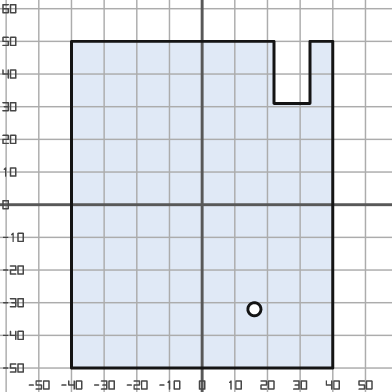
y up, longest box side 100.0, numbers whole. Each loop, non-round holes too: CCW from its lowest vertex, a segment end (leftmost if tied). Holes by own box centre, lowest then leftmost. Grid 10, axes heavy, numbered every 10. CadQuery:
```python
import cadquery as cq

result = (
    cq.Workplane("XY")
    .moveTo(-40.0, -50.0)
    .lineTo(40.0, -50.0)
    .lineTo(40.0, 50.0)
    .lineTo(33.0, 50.0)
    .lineTo(33.0, 31.0)
    .lineTo(22.0, 31.0)
    .lineTo(22.0, 50.0)
    .lineTo(-40.0, 50.0)
    .close()
    .moveTo(16.0, -32.0)
    .circle(2.0)
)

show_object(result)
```